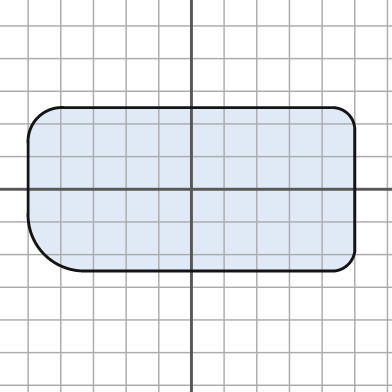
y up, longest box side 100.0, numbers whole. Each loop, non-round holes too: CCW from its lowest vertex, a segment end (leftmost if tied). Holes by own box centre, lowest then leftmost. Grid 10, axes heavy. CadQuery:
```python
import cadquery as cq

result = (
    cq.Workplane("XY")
    .moveTo(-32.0, -25.0)
    .lineTo(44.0, -25.0)
    .threePointArc((48.0, -23.0), (50.0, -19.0))
    .lineTo(50.0, 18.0)
    .threePointArc((48.0, 23.0), (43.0, 25.0))
    .lineTo(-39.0, 25.0)
    .threePointArc((-47.0, 22.0), (-50.0, 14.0))
    .lineTo(-50.0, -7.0)
    .threePointArc((-45.0, -20.0), (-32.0, -25.0))
    .close()
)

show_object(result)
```